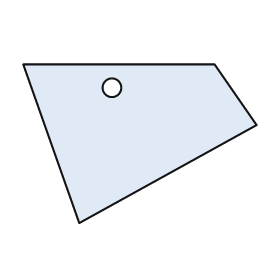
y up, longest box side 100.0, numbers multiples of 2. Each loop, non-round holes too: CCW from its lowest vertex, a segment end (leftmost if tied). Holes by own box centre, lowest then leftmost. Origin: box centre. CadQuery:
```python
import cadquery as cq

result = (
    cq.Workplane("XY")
    .moveTo(-26.0, -34.0)
    .lineTo(50.0, 8.0)
    .lineTo(32.0, 34.0)
    .lineTo(-50.0, 34.0)
    .close()
    .moveTo(-12.0, 24.0)
    .circle(4.0)
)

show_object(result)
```